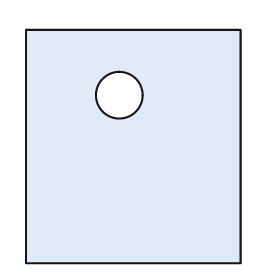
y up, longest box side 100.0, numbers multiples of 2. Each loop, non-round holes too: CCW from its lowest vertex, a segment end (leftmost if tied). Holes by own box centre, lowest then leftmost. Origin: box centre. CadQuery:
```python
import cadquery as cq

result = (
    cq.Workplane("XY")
    .moveTo(-46.0, -50.0)
    .lineTo(46.0, -50.0)
    .lineTo(46.0, 50.0)
    .lineTo(-46.0, 50.0)
    .close()
    .moveTo(-6.0, 22.0)
    .circle(10.0)
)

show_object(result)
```